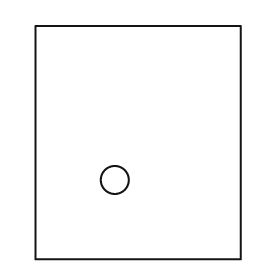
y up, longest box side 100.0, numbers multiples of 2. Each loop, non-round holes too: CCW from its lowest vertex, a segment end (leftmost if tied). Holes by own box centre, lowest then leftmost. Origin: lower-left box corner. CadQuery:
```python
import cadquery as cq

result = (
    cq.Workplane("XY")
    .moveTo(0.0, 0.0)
    .lineTo(88.0, 0.0)
    .lineTo(88.0, 100.0)
    .lineTo(0.0, 100.0)
    .close()
    .moveTo(34.0, 34.0)
    .circle(6.0)
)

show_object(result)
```